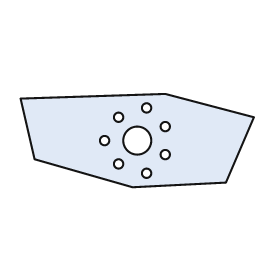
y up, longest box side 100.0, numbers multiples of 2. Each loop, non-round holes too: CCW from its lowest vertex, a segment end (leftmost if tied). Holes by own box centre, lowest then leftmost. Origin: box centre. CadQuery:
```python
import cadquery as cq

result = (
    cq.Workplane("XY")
    .moveTo(-2.0, -20.0)
    .lineTo(38.0, -18.0)
    .lineTo(50.0, 10.0)
    .lineTo(12.0, 20.0)
    .lineTo(-50.0, 18.0)
    .lineTo(-44.0, -8.0)
    .close()
    .moveTo(4.0, -14.0)
    .circle(2.0)
    .moveTo(-8.0, -10.0)
    .circle(2.0)
    .moveTo(12.0, -6.0)
    .circle(2.0)
    .moveTo(-14.0, 0.0)
    .circle(2.0)
    .moveTo(0.0, 0.0)
    .circle(6.0)
    .moveTo(12.0, 6.0)
    .circle(2.0)
    .moveTo(-8.0, 10.0)
    .circle(2.0)
    .moveTo(4.0, 14.0)
    .circle(2.0)
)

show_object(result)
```